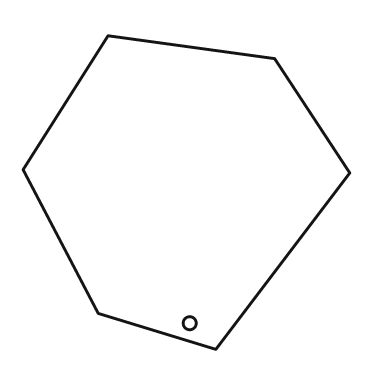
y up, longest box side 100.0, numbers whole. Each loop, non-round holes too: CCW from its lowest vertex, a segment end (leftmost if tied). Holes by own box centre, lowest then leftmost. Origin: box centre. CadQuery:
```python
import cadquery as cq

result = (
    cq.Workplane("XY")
    .moveTo(9.0, -48.0)
    .lineTo(50.0, 6.0)
    .lineTo(27.0, 41.0)
    .lineTo(-24.0, 48.0)
    .lineTo(-50.0, 7.0)
    .lineTo(-27.0, -37.0)
    .close()
    .moveTo(1.0, -40.0)
    .circle(2.0)
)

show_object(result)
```